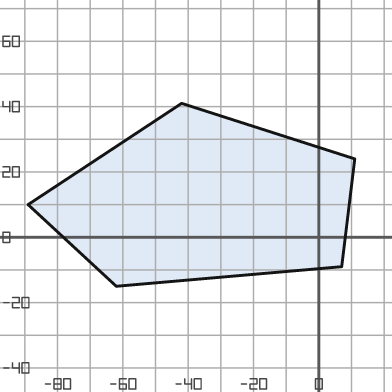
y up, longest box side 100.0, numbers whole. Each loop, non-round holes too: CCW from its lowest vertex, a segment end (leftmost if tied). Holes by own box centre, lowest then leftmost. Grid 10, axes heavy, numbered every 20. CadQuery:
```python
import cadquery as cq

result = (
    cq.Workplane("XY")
    .moveTo(-62.0, -15.0)
    .lineTo(7.0, -9.0)
    .lineTo(11.0, 24.0)
    .lineTo(-42.0, 41.0)
    .lineTo(-89.0, 10.0)
    .close()
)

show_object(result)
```